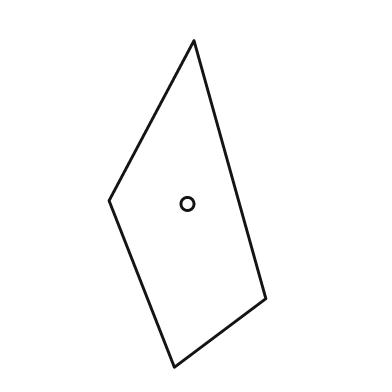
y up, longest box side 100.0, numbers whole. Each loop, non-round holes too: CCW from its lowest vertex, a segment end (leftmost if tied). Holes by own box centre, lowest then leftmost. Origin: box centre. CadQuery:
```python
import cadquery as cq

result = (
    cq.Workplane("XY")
    .moveTo(-4.0, -50.0)
    .lineTo(24.0, -29.0)
    .lineTo(2.0, 50.0)
    .lineTo(-24.0, 1.0)
    .close()
    .moveTo(0.0, 0.0)
    .circle(2.0)
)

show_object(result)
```